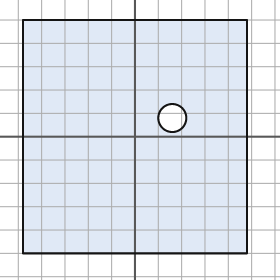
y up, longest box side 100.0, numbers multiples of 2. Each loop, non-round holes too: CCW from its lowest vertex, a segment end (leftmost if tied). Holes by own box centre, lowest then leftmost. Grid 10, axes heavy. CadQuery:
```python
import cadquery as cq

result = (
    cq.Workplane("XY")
    .moveTo(-48.0, -50.0)
    .lineTo(48.0, -50.0)
    .lineTo(48.0, 50.0)
    .lineTo(-48.0, 50.0)
    .close()
    .moveTo(16.0, 8.0)
    .circle(6.0)
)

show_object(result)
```